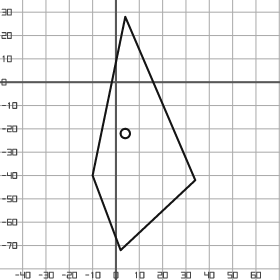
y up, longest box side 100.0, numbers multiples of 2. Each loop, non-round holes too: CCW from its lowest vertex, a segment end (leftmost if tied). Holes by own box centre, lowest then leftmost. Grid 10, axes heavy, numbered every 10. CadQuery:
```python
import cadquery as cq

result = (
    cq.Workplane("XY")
    .moveTo(2.0, -72.0)
    .lineTo(34.0, -42.0)
    .lineTo(4.0, 28.0)
    .lineTo(-10.0, -40.0)
    .close()
    .moveTo(4.0, -22.0)
    .circle(2.0)
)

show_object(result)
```